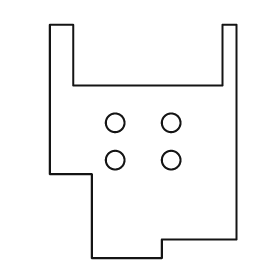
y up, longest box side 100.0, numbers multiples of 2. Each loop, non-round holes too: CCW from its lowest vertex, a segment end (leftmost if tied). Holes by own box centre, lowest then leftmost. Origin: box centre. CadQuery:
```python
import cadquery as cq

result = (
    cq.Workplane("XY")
    .moveTo(-22.0, -50.0)
    .lineTo(8.0, -50.0)
    .lineTo(8.0, -42.0)
    .lineTo(40.0, -42.0)
    .lineTo(40.0, 50.0)
    .lineTo(34.0, 50.0)
    .lineTo(34.0, 24.0)
    .lineTo(-30.0, 24.0)
    .lineTo(-30.0, 50.0)
    .lineTo(-40.0, 50.0)
    .lineTo(-40.0, -14.0)
    .lineTo(-22.0, -14.0)
    .close()
    .moveTo(-12.0, -8.0)
    .circle(4.0)
    .moveTo(12.0, -8.0)
    .circle(4.0)
    .moveTo(-12.0, 8.0)
    .circle(4.0)
    .moveTo(12.0, 8.0)
    .circle(4.0)
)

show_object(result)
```